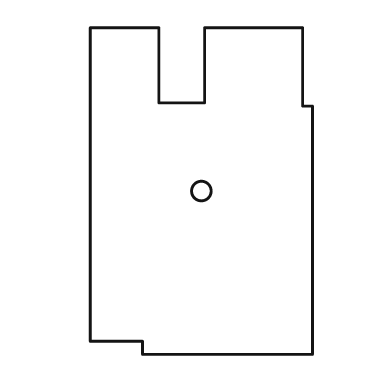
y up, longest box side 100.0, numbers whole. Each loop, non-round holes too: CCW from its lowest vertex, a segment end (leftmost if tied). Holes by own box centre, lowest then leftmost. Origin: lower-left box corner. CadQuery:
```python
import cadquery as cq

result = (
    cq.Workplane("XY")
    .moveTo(16.0, 0.0)
    .lineTo(68.0, 0.0)
    .lineTo(68.0, 76.0)
    .lineTo(65.0, 76.0)
    .lineTo(65.0, 100.0)
    .lineTo(35.0, 100.0)
    .lineTo(35.0, 77.0)
    .lineTo(21.0, 77.0)
    .lineTo(21.0, 100.0)
    .lineTo(0.0, 100.0)
    .lineTo(0.0, 4.0)
    .lineTo(16.0, 4.0)
    .close()
    .moveTo(34.0, 50.0)
    .circle(3.0)
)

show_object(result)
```